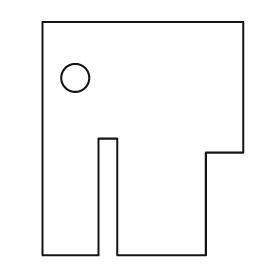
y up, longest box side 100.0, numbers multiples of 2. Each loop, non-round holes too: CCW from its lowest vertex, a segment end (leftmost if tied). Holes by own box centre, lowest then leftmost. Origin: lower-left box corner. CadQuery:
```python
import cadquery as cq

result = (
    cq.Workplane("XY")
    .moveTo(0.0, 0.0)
    .lineTo(24.0, 0.0)
    .lineTo(24.0, 50.0)
    .lineTo(32.0, 50.0)
    .lineTo(32.0, 0.0)
    .lineTo(70.0, 0.0)
    .lineTo(70.0, 44.0)
    .lineTo(86.0, 44.0)
    .lineTo(86.0, 100.0)
    .lineTo(0.0, 100.0)
    .close()
    .moveTo(14.0, 76.0)
    .circle(6.0)
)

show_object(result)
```